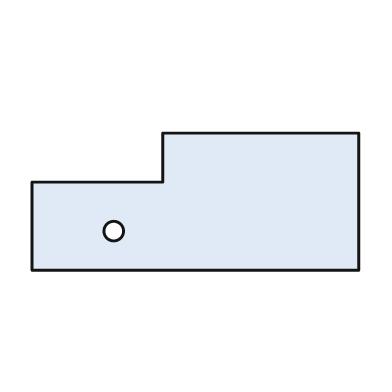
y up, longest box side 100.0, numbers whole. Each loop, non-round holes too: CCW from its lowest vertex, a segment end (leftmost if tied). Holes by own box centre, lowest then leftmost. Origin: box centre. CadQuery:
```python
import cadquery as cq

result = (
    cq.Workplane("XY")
    .moveTo(-50.0, -21.0)
    .lineTo(50.0, -21.0)
    .lineTo(50.0, 21.0)
    .lineTo(-10.0, 21.0)
    .lineTo(-10.0, 6.0)
    .lineTo(-50.0, 6.0)
    .close()
    .moveTo(-25.0, -9.0)
    .circle(3.0)
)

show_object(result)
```